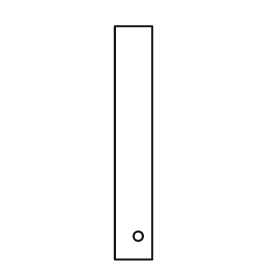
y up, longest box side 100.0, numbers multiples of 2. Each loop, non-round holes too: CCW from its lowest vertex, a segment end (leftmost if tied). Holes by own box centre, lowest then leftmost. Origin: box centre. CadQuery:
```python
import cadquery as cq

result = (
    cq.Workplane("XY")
    .moveTo(-8.0, -50.0)
    .lineTo(8.0, -50.0)
    .lineTo(8.0, 50.0)
    .lineTo(-8.0, 50.0)
    .close()
    .moveTo(2.0, -40.0)
    .circle(2.0)
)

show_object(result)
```